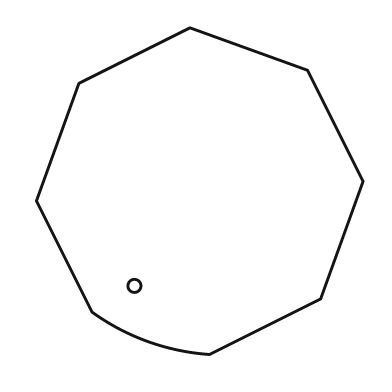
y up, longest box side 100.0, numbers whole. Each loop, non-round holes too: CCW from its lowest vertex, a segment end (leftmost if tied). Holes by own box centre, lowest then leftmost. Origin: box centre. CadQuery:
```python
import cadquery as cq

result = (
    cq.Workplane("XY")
    .moveTo(3.0, -50.0)
    .lineTo(37.0, -33.0)
    .lineTo(50.0, 3.0)
    .lineTo(33.0, 37.0)
    .lineTo(-3.0, 50.0)
    .lineTo(-37.0, 33.0)
    .lineTo(-50.0, -3.0)
    .lineTo(-33.0, -37.0)
    .threePointArc((-16.0, -46.0), (3.0, -50.0))
    .close()
    .moveTo(-20.0, -29.0)
    .circle(2.0)
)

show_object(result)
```